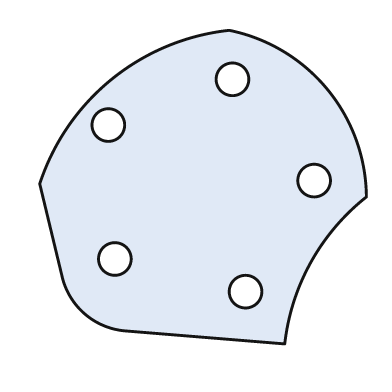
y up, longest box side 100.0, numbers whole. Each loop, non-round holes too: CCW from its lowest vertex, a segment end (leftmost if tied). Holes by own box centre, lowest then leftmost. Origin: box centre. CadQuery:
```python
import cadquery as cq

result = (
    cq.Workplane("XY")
    .moveTo(25.0, -48.0)
    .threePointArc((33.0, -23.0), (50.0, -3.0))
    .threePointArc((38.0, 30.0), (8.0, 48.0))
    .threePointArc((-28.0, 33.0), (-50.0, 1.0))
    .lineTo(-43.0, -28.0)
    .threePointArc((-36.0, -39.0), (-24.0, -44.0))
    .close()
    .moveTo(13.0, -32.0)
    .circle(5.0)
    .moveTo(-27.0, -22.0)
    .circle(5.0)
    .moveTo(34.0, 2.0)
    .circle(5.0)
    .moveTo(-29.0, 19.0)
    .circle(5.0)
    .moveTo(9.0, 33.0)
    .circle(5.0)
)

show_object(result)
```